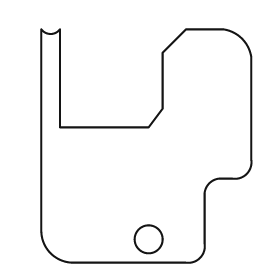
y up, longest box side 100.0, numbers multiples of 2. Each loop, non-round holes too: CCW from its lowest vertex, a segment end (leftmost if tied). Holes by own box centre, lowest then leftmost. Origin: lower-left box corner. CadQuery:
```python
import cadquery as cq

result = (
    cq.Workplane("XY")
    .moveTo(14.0, 0.0)
    .lineTo(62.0, 0.0)
    .threePointArc((68.0, 2.0), (70.0, 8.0))
    .lineTo(70.0, 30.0)
    .threePointArc((72.0, 34.0), (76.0, 36.0))
    .lineTo(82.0, 36.0)
    .threePointArc((88.0, 38.0), (90.0, 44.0))
    .lineTo(90.0, 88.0)
    .threePointArc((86.0, 96.0), (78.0, 100.0))
    .lineTo(62.0, 100.0)
    .lineTo(52.0, 90.0)
    .lineTo(52.0, 66.0)
    .lineTo(46.0, 58.0)
    .lineTo(8.0, 58.0)
    .lineTo(8.0, 100.0)
    .threePointArc((4.0, 98.0), (0.0, 100.0))
    .lineTo(0.0, 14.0)
    .threePointArc((4.0, 4.0), (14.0, 0.0))
    .close()
    .moveTo(46.0, 10.0)
    .circle(6.0)
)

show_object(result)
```